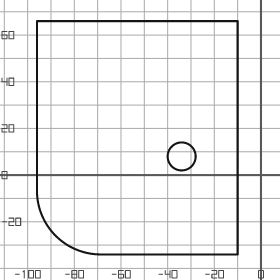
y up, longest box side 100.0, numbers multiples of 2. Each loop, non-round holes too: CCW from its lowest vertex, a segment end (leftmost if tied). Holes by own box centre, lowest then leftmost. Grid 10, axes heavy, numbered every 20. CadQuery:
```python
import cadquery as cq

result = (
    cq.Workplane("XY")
    .moveTo(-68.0, -34.0)
    .lineTo(-10.0, -34.0)
    .lineTo(-10.0, 66.0)
    .lineTo(-96.0, 66.0)
    .lineTo(-96.0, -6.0)
    .threePointArc((-88.0, -26.0), (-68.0, -34.0))
    .close()
    .moveTo(-34.0, 8.0)
    .circle(6.0)
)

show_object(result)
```